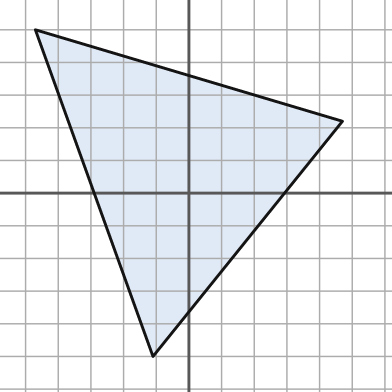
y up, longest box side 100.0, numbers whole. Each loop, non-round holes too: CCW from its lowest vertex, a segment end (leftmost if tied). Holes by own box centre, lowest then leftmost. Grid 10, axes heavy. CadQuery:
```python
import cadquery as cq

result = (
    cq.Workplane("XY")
    .moveTo(-11.0, -50.0)
    .lineTo(47.0, 22.0)
    .lineTo(-47.0, 50.0)
    .close()
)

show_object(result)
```